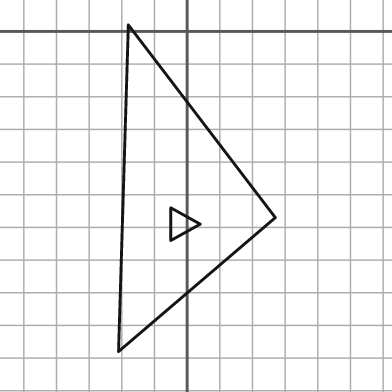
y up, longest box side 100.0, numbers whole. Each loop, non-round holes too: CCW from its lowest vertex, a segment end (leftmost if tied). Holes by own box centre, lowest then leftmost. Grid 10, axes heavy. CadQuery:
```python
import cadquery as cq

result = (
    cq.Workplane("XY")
    .moveTo(-21.0, -98.0)
    .lineTo(27.0, -57.0)
    .lineTo(-18.0, 2.0)
    .close()
    .moveTo(-5.0, -64.0)
    .lineTo(4.0, -59.0)
    .lineTo(-5.0, -54.0)
    .close()
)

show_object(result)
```